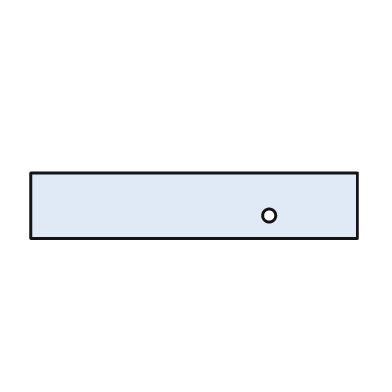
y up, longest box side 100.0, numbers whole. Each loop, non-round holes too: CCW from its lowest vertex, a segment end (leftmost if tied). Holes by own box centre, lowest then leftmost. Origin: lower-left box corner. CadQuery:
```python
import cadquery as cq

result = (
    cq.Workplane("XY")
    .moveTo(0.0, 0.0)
    .lineTo(100.0, 0.0)
    .lineTo(100.0, 20.0)
    .lineTo(0.0, 20.0)
    .close()
    .moveTo(73.0, 7.0)
    .circle(2.0)
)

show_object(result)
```